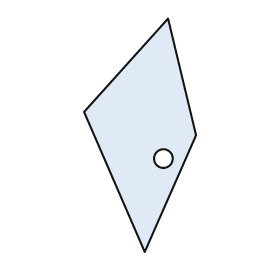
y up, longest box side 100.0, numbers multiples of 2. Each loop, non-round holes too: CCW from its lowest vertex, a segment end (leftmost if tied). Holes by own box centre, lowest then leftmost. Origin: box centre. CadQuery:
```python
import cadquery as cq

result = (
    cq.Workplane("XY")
    .moveTo(2.0, -50.0)
    .lineTo(24.0, 0.0)
    .lineTo(12.0, 50.0)
    .lineTo(-24.0, 10.0)
    .close()
    .moveTo(10.0, -10.0)
    .circle(4.0)
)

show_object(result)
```